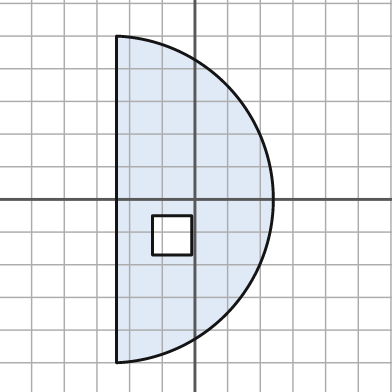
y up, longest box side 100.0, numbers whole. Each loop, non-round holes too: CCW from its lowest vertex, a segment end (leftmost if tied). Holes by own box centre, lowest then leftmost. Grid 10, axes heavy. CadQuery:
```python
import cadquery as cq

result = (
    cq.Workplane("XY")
    .moveTo(-24.0, -50.0)
    .threePointArc((24.0, 0.0), (-24.0, 50.0))
    .close()
    .moveTo(-13.0, -17.0)
    .lineTo(-1.0, -17.0)
    .lineTo(-1.0, -5.0)
    .lineTo(-13.0, -5.0)
    .close()
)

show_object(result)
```